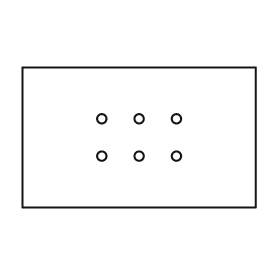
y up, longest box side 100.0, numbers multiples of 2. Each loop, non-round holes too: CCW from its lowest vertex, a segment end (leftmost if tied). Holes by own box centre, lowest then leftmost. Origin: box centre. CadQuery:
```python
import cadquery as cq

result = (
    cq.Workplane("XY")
    .moveTo(-50.0, -30.0)
    .lineTo(50.0, -30.0)
    .lineTo(50.0, 30.0)
    .lineTo(-50.0, 30.0)
    .close()
    .moveTo(-16.0, -8.0)
    .circle(2.0)
    .moveTo(0.0, -8.0)
    .circle(2.0)
    .moveTo(16.0, -8.0)
    .circle(2.0)
    .moveTo(-16.0, 8.0)
    .circle(2.0)
    .moveTo(0.0, 8.0)
    .circle(2.0)
    .moveTo(16.0, 8.0)
    .circle(2.0)
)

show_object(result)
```